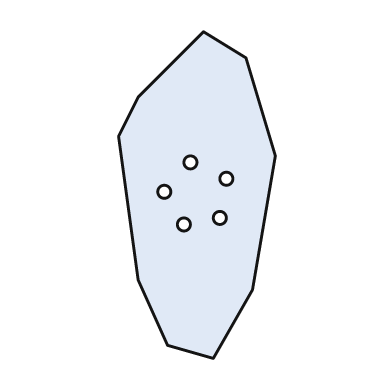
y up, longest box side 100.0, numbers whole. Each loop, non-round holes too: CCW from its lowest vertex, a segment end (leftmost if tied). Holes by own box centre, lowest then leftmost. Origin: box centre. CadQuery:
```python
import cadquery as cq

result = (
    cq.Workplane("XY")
    .moveTo(5.0, -50.0)
    .lineTo(17.0, -29.0)
    .lineTo(24.0, 12.0)
    .lineTo(15.0, 42.0)
    .lineTo(2.0, 50.0)
    .lineTo(-18.0, 30.0)
    .lineTo(-24.0, 18.0)
    .lineTo(-18.0, -26.0)
    .lineTo(-9.0, -46.0)
    .close()
    .moveTo(-4.0, -9.0)
    .circle(2.0)
    .moveTo(7.0, -7.0)
    .circle(2.0)
    .moveTo(-10.0, 1.0)
    .circle(2.0)
    .moveTo(9.0, 5.0)
    .circle(2.0)
    .moveTo(-2.0, 10.0)
    .circle(2.0)
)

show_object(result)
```